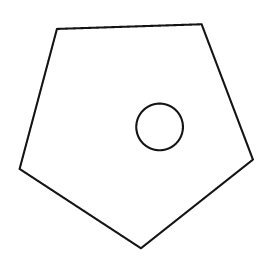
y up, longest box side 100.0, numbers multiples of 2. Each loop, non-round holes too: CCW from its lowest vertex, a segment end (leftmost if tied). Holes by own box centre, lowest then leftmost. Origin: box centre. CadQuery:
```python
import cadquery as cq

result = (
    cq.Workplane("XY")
    .moveTo(2.0, -48.0)
    .lineTo(50.0, -10.0)
    .lineTo(28.0, 48.0)
    .lineTo(-34.0, 46.0)
    .lineTo(-50.0, -14.0)
    .close()
    .moveTo(10.0, 4.0)
    .circle(10.0)
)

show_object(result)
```